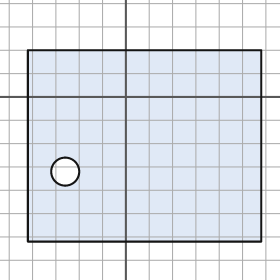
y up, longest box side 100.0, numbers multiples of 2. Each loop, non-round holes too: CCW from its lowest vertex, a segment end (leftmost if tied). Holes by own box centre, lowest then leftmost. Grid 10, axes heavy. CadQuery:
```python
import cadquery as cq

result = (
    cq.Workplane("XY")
    .moveTo(-42.0, -62.0)
    .lineTo(58.0, -62.0)
    .lineTo(58.0, 20.0)
    .lineTo(-42.0, 20.0)
    .close()
    .moveTo(-26.0, -32.0)
    .circle(6.0)
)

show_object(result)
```